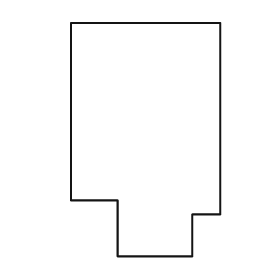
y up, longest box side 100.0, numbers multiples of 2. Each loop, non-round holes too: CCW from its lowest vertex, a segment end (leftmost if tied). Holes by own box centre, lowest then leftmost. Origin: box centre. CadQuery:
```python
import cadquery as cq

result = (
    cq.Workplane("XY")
    .moveTo(-12.0, -50.0)
    .lineTo(20.0, -50.0)
    .lineTo(20.0, -32.0)
    .lineTo(32.0, -32.0)
    .lineTo(32.0, 50.0)
    .lineTo(-32.0, 50.0)
    .lineTo(-32.0, -26.0)
    .lineTo(-12.0, -26.0)
    .close()
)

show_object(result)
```